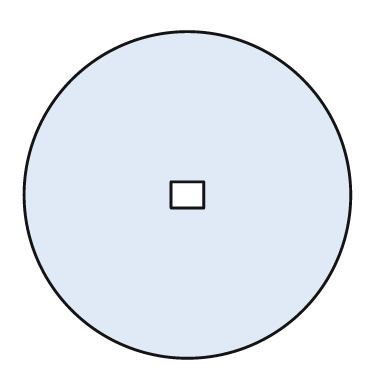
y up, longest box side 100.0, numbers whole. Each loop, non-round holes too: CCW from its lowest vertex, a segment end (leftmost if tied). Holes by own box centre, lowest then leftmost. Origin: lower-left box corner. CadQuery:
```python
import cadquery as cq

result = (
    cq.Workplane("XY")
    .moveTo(50.0, 50.0)
    .circle(50.0)
    .moveTo(45.0, 46.0)
    .lineTo(55.0, 46.0)
    .lineTo(55.0, 54.0)
    .lineTo(45.0, 54.0)
    .close()
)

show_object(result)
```